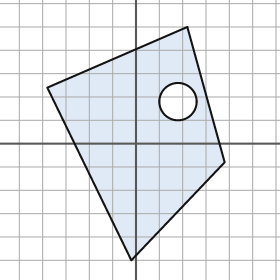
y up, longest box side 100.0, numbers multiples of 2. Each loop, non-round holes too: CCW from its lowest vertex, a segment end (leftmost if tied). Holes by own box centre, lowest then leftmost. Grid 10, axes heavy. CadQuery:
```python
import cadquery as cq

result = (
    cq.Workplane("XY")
    .moveTo(-2.0, -50.0)
    .lineTo(38.0, -8.0)
    .lineTo(22.0, 50.0)
    .lineTo(-38.0, 24.0)
    .close()
    .moveTo(18.0, 18.0)
    .circle(8.0)
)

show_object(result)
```